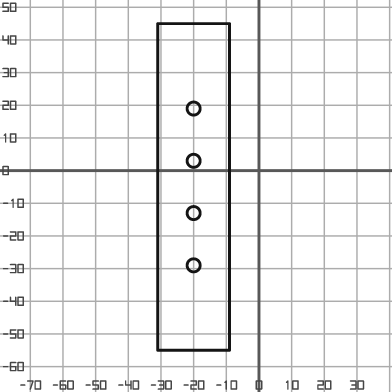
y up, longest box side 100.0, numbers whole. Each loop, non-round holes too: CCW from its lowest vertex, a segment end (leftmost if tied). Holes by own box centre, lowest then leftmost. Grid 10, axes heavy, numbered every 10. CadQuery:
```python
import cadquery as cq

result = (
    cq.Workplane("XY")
    .moveTo(-31.0, -55.0)
    .lineTo(-9.0, -55.0)
    .lineTo(-9.0, 45.0)
    .lineTo(-31.0, 45.0)
    .close()
    .moveTo(-20.0, -29.0)
    .circle(2.0)
    .moveTo(-20.0, -13.0)
    .circle(2.0)
    .moveTo(-20.0, 3.0)
    .circle(2.0)
    .moveTo(-20.0, 19.0)
    .circle(2.0)
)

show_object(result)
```